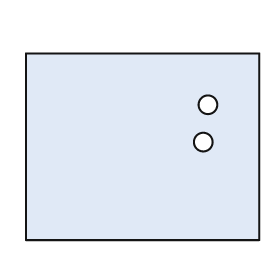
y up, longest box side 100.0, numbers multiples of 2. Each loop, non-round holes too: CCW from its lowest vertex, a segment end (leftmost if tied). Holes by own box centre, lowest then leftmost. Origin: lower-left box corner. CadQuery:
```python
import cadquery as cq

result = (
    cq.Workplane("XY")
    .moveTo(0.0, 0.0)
    .lineTo(100.0, 0.0)
    .lineTo(100.0, 80.0)
    .lineTo(0.0, 80.0)
    .close()
    .moveTo(76.0, 42.0)
    .circle(4.0)
    .moveTo(78.0, 58.0)
    .circle(4.0)
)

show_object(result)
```